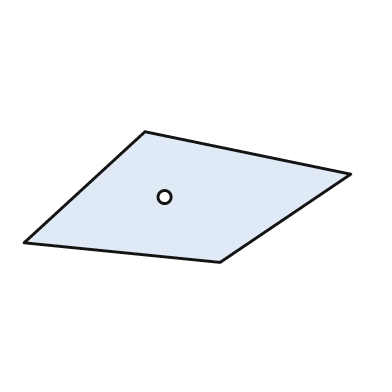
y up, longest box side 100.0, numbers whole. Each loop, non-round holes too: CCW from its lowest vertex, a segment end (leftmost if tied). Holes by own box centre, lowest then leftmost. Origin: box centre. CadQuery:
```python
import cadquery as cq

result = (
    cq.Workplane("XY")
    .moveTo(10.0, -20.0)
    .lineTo(50.0, 7.0)
    .lineTo(-13.0, 20.0)
    .lineTo(-50.0, -14.0)
    .close()
    .moveTo(-7.0, 0.0)
    .circle(2.0)
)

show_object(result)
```